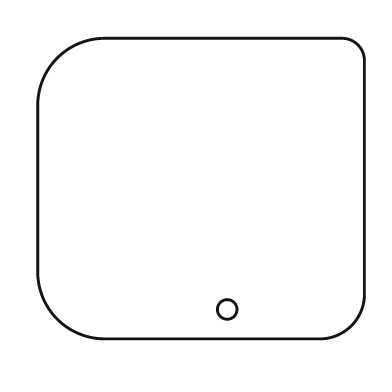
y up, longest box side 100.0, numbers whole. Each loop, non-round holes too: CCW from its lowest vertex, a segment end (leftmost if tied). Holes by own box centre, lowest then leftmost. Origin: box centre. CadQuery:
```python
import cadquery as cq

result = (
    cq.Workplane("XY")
    .moveTo(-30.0, -46.0)
    .lineTo(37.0, -46.0)
    .threePointArc((46.0, -42.0), (50.0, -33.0))
    .lineTo(50.0, 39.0)
    .threePointArc((48.0, 44.0), (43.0, 46.0))
    .lineTo(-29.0, 46.0)
    .threePointArc((-44.0, 40.0), (-50.0, 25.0))
    .lineTo(-50.0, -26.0)
    .threePointArc((-44.0, -40.0), (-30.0, -46.0))
    .close()
    .moveTo(8.0, -37.0)
    .circle(3.0)
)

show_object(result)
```